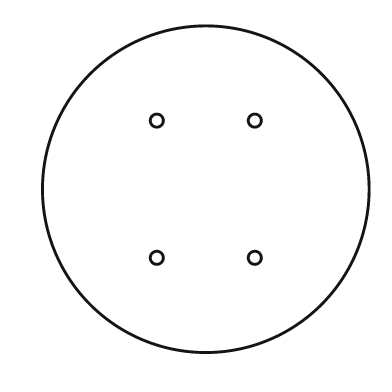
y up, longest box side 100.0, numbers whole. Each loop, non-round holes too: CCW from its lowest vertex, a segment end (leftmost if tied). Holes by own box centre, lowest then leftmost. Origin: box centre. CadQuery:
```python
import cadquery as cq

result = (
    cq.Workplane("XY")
    .moveTo(0.0, 0.0)
    .circle(50.0)
    .moveTo(-15.0, -21.0)
    .circle(2.0)
    .moveTo(15.0, -21.0)
    .circle(2.0)
    .moveTo(-15.0, 21.0)
    .circle(2.0)
    .moveTo(15.0, 21.0)
    .circle(2.0)
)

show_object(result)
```